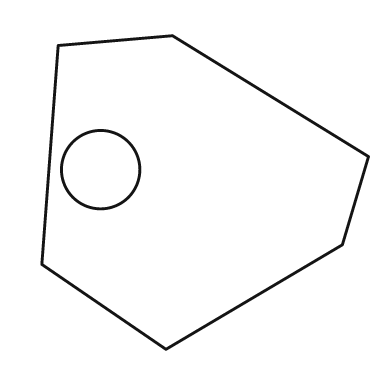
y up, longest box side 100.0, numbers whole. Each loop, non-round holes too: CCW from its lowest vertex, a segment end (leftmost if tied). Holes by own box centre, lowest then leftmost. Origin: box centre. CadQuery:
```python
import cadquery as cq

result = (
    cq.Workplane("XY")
    .moveTo(-12.0, -48.0)
    .lineTo(42.0, -16.0)
    .lineTo(50.0, 11.0)
    .lineTo(-10.0, 48.0)
    .lineTo(-45.0, 45.0)
    .lineTo(-50.0, -22.0)
    .close()
    .moveTo(-32.0, 7.0)
    .circle(12.0)
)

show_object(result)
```